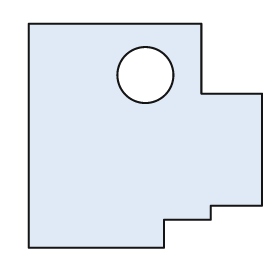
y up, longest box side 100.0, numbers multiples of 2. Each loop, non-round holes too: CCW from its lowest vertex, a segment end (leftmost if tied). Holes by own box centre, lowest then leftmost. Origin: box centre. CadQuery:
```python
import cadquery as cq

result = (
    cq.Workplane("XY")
    .moveTo(-50.0, -48.0)
    .lineTo(8.0, -48.0)
    .lineTo(8.0, -36.0)
    .lineTo(28.0, -36.0)
    .lineTo(28.0, -30.0)
    .lineTo(50.0, -30.0)
    .lineTo(50.0, 18.0)
    .lineTo(24.0, 18.0)
    .lineTo(24.0, 48.0)
    .lineTo(-50.0, 48.0)
    .close()
    .moveTo(0.0, 26.0)
    .circle(12.0)
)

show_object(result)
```